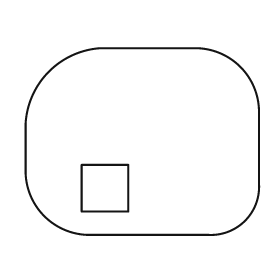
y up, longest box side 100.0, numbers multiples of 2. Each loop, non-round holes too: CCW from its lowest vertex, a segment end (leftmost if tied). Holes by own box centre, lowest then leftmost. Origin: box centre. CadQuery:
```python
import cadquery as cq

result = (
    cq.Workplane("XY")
    .moveTo(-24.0, -40.0)
    .lineTo(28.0, -40.0)
    .threePointArc((44.0, -34.0), (50.0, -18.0))
    .lineTo(50.0, 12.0)
    .threePointArc((42.0, 32.0), (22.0, 40.0))
    .lineTo(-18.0, 40.0)
    .threePointArc((-40.0, 30.0), (-50.0, 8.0))
    .lineTo(-50.0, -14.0)
    .threePointArc((-42.0, -32.0), (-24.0, -40.0))
    .close()
    .moveTo(-26.0, -30.0)
    .lineTo(-6.0, -30.0)
    .lineTo(-6.0, -10.0)
    .lineTo(-26.0, -10.0)
    .close()
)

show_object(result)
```